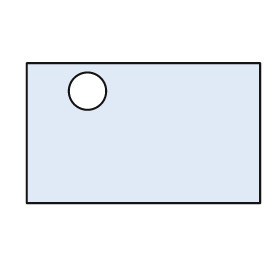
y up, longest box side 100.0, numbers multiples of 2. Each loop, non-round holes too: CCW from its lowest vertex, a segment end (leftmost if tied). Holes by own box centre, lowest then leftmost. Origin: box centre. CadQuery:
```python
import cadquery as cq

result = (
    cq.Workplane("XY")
    .moveTo(-50.0, -30.0)
    .lineTo(50.0, -30.0)
    .lineTo(50.0, 30.0)
    .lineTo(-50.0, 30.0)
    .close()
    .moveTo(-24.0, 18.0)
    .circle(8.0)
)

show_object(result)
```